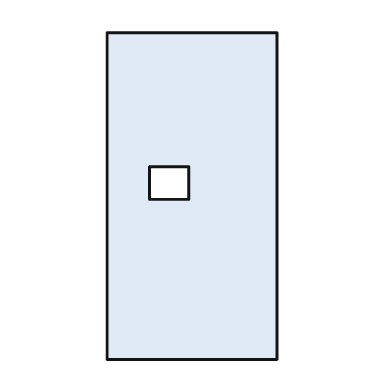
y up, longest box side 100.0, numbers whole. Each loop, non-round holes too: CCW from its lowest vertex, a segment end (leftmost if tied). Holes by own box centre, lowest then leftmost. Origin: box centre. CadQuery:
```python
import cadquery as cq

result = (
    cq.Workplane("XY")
    .moveTo(-26.0, -50.0)
    .lineTo(26.0, -50.0)
    .lineTo(26.0, 50.0)
    .lineTo(-26.0, 50.0)
    .close()
    .moveTo(-13.0, -1.0)
    .lineTo(-1.0, -1.0)
    .lineTo(-1.0, 9.0)
    .lineTo(-13.0, 9.0)
    .close()
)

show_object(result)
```